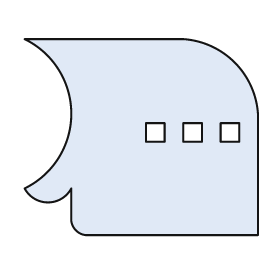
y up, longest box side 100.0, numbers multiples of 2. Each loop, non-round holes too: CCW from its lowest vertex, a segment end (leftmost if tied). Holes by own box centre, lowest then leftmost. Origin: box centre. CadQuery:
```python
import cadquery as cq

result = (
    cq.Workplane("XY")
    .moveTo(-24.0, -42.0)
    .lineTo(50.0, -42.0)
    .lineTo(50.0, 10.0)
    .threePointArc((40.0, 32.0), (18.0, 42.0))
    .lineTo(-50.0, 42.0)
    .threePointArc((-30.0, 10.0), (-50.0, -22.0))
    .threePointArc((-40.0, -28.0), (-30.0, -22.0))
    .lineTo(-30.0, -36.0)
    .threePointArc((-28.0, -40.0), (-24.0, -42.0))
    .close()
    .moveTo(2.0, -2.0)
    .lineTo(10.0, -2.0)
    .lineTo(10.0, 6.0)
    .lineTo(2.0, 6.0)
    .close()
    .moveTo(18.0, -2.0)
    .lineTo(26.0, -2.0)
    .lineTo(26.0, 6.0)
    .lineTo(18.0, 6.0)
    .close()
    .moveTo(34.0, -2.0)
    .lineTo(42.0, -2.0)
    .lineTo(42.0, 6.0)
    .lineTo(34.0, 6.0)
    .close()
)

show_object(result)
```